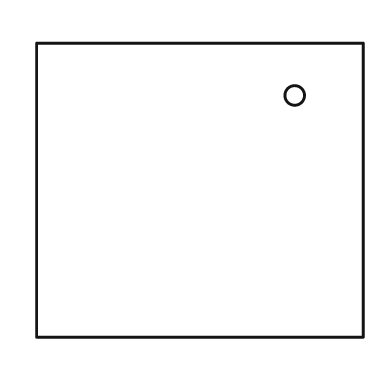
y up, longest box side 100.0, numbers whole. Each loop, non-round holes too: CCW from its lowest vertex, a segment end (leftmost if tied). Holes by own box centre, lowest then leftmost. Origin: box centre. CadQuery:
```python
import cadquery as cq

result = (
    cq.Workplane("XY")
    .moveTo(-50.0, -45.0)
    .lineTo(50.0, -45.0)
    .lineTo(50.0, 45.0)
    .lineTo(-50.0, 45.0)
    .close()
    .moveTo(29.0, 29.0)
    .circle(3.0)
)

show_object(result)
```